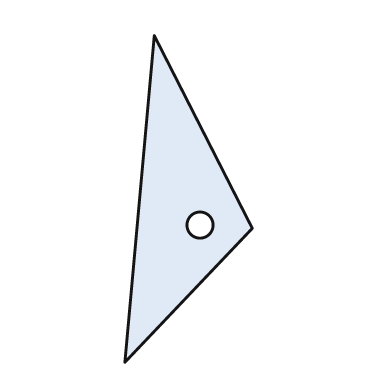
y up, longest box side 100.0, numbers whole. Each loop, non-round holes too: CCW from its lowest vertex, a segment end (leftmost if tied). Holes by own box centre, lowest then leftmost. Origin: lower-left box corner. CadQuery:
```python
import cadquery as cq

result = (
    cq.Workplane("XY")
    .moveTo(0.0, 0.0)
    .lineTo(39.0, 41.0)
    .lineTo(9.0, 100.0)
    .close()
    .moveTo(23.0, 42.0)
    .circle(4.0)
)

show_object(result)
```